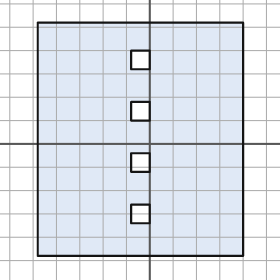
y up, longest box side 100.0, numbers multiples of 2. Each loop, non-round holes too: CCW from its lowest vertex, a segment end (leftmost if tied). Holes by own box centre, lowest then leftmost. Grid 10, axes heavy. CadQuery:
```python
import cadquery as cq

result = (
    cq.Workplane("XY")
    .moveTo(-48.0, -48.0)
    .lineTo(40.0, -48.0)
    .lineTo(40.0, 52.0)
    .lineTo(-48.0, 52.0)
    .close()
    .moveTo(-8.0, -34.0)
    .lineTo(0.0, -34.0)
    .lineTo(0.0, -26.0)
    .lineTo(-8.0, -26.0)
    .close()
    .moveTo(-8.0, -12.0)
    .lineTo(0.0, -12.0)
    .lineTo(0.0, -4.0)
    .lineTo(-8.0, -4.0)
    .close()
    .moveTo(-8.0, 10.0)
    .lineTo(0.0, 10.0)
    .lineTo(0.0, 18.0)
    .lineTo(-8.0, 18.0)
    .close()
    .moveTo(-8.0, 32.0)
    .lineTo(0.0, 32.0)
    .lineTo(0.0, 40.0)
    .lineTo(-8.0, 40.0)
    .close()
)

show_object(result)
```